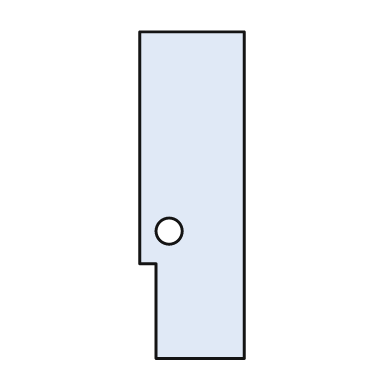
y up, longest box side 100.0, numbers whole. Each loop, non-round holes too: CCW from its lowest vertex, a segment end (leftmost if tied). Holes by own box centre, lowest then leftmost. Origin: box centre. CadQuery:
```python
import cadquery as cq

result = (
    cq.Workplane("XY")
    .moveTo(-11.0, -50.0)
    .lineTo(16.0, -50.0)
    .lineTo(16.0, 50.0)
    .lineTo(-16.0, 50.0)
    .lineTo(-16.0, -21.0)
    .lineTo(-11.0, -21.0)
    .close()
    .moveTo(-7.0, -11.0)
    .circle(4.0)
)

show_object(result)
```